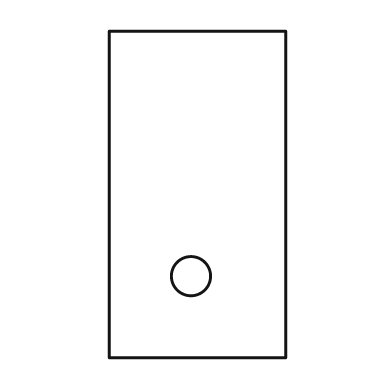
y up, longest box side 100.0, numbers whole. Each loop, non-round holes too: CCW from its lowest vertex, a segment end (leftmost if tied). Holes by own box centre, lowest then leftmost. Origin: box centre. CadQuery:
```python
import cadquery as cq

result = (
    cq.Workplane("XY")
    .moveTo(-27.0, -50.0)
    .lineTo(27.0, -50.0)
    .lineTo(27.0, 50.0)
    .lineTo(-27.0, 50.0)
    .close()
    .moveTo(-2.0, -25.0)
    .circle(6.0)
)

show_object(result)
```